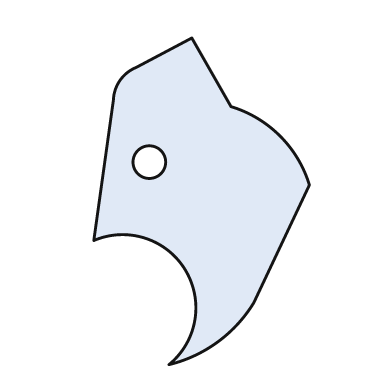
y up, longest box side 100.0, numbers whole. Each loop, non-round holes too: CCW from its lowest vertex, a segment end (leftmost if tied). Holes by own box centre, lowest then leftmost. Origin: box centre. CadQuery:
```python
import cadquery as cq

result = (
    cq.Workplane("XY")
    .moveTo(-10.0, -50.0)
    .threePointArc((5.0, -43.0), (16.0, -31.0))
    .lineTo(33.0, 5.0)
    .threePointArc((24.0, 20.0), (9.0, 29.0))
    .lineTo(-3.0, 50.0)
    .lineTo(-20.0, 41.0)
    .threePointArc((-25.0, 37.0), (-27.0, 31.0))
    .lineTo(-33.0, -12.0)
    .threePointArc((-5.0, -21.0), (-10.0, -50.0))
    .close()
    .moveTo(-16.0, 12.0)
    .circle(5.0)
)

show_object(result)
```